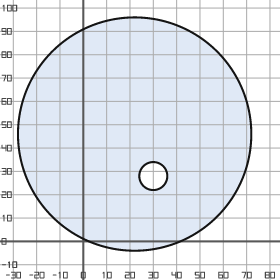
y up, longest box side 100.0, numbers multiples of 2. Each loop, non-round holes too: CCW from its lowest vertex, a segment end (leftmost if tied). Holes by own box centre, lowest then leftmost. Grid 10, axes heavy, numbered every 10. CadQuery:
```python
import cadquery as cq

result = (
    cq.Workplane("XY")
    .moveTo(22.0, 46.0)
    .circle(50.0)
    .moveTo(30.0, 28.0)
    .circle(6.0)
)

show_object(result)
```